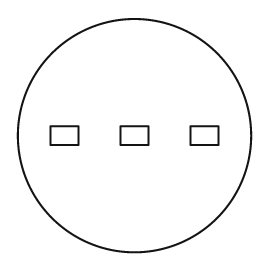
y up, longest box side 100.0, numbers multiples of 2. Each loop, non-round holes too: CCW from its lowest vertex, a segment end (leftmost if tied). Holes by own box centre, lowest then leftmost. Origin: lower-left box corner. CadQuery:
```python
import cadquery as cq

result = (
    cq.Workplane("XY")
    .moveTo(50.0, 50.0)
    .circle(50.0)
    .moveTo(14.0, 46.0)
    .lineTo(26.0, 46.0)
    .lineTo(26.0, 54.0)
    .lineTo(14.0, 54.0)
    .close()
    .moveTo(44.0, 46.0)
    .lineTo(56.0, 46.0)
    .lineTo(56.0, 54.0)
    .lineTo(44.0, 54.0)
    .close()
    .moveTo(74.0, 46.0)
    .lineTo(86.0, 46.0)
    .lineTo(86.0, 54.0)
    .lineTo(74.0, 54.0)
    .close()
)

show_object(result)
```